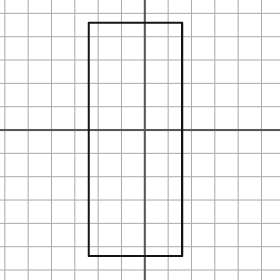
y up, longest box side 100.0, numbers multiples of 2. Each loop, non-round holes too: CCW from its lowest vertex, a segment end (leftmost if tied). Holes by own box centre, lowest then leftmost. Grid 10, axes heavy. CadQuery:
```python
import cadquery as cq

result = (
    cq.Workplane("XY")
    .moveTo(-24.0, -54.0)
    .lineTo(16.0, -54.0)
    .lineTo(16.0, 46.0)
    .lineTo(-24.0, 46.0)
    .close()
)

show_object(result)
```